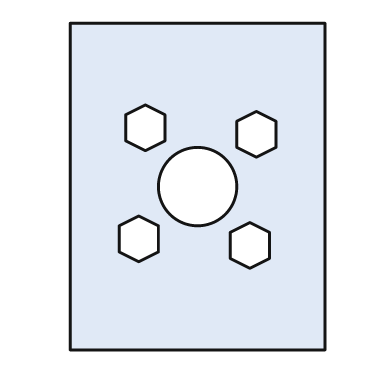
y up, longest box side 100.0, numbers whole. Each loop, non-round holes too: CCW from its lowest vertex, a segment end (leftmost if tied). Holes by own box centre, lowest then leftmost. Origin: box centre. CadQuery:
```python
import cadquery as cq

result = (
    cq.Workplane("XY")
    .moveTo(-39.0, -50.0)
    .lineTo(39.0, -50.0)
    .lineTo(39.0, 50.0)
    .lineTo(-39.0, 50.0)
    .close()
    .moveTo(16.0, -25.0)
    .lineTo(22.0, -22.0)
    .lineTo(22.0, -14.0)
    .lineTo(16.0, -11.0)
    .lineTo(10.0, -14.0)
    .lineTo(10.0, -22.0)
    .close()
    .moveTo(-18.0, -23.0)
    .lineTo(-12.0, -20.0)
    .lineTo(-12.0, -12.0)
    .lineTo(-18.0, -9.0)
    .lineTo(-24.0, -12.0)
    .lineTo(-24.0, -20.0)
    .close()
    .moveTo(0.0, 0.0)
    .circle(12.0)
    .moveTo(18.0, 9.0)
    .lineTo(24.0, 12.0)
    .lineTo(24.0, 20.0)
    .lineTo(18.0, 23.0)
    .lineTo(12.0, 20.0)
    .lineTo(12.0, 12.0)
    .close()
    .moveTo(-16.0, 11.0)
    .lineTo(-10.0, 14.0)
    .lineTo(-10.0, 22.0)
    .lineTo(-16.0, 25.0)
    .lineTo(-22.0, 22.0)
    .lineTo(-22.0, 14.0)
    .close()
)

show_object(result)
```